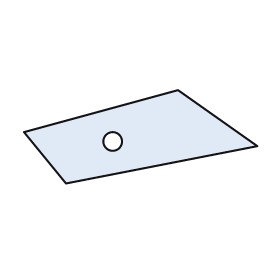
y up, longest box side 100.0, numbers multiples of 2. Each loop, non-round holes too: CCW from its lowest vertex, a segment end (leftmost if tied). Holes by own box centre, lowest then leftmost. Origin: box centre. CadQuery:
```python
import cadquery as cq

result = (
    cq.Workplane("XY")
    .moveTo(-32.0, -20.0)
    .lineTo(50.0, -4.0)
    .lineTo(16.0, 20.0)
    .lineTo(-50.0, 2.0)
    .close()
    .moveTo(-12.0, -2.0)
    .circle(4.0)
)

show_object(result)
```